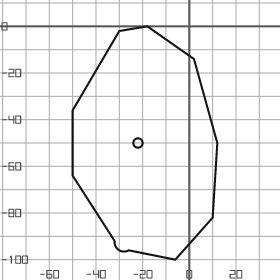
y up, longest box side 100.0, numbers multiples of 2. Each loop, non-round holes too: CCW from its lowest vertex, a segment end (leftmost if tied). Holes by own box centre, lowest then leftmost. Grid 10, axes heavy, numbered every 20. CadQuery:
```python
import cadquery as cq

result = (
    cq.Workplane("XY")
    .moveTo(-6.0, -100.0)
    .lineTo(10.0, -82.0)
    .lineTo(12.0, -50.0)
    .lineTo(2.0, -14.0)
    .lineTo(-18.0, 0.0)
    .lineTo(-30.0, -2.0)
    .lineTo(-50.0, -36.0)
    .lineTo(-50.0, -64.0)
    .lineTo(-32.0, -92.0)
    .threePointArc((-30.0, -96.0), (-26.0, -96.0))
    .close()
    .moveTo(-22.0, -50.0)
    .circle(2.0)
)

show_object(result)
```